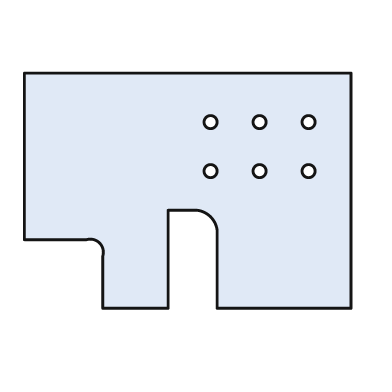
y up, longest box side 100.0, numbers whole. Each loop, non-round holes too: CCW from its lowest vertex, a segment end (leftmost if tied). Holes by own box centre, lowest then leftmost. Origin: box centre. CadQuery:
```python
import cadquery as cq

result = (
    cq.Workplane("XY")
    .moveTo(-26.0, -36.0)
    .lineTo(-6.0, -36.0)
    .lineTo(-6.0, -6.0)
    .lineTo(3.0, -6.0)
    .threePointArc((7.0, -8.0), (9.0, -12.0))
    .lineTo(9.0, -36.0)
    .lineTo(50.0, -36.0)
    .lineTo(50.0, 36.0)
    .lineTo(-50.0, 36.0)
    .lineTo(-50.0, -15.0)
    .lineTo(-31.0, -15.0)
    .threePointArc((-27.0, -16.0), (-26.0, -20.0))
    .close()
    .moveTo(7.0, 6.0)
    .circle(2.0)
    .moveTo(22.0, 6.0)
    .circle(2.0)
    .moveTo(37.0, 6.0)
    .circle(2.0)
    .moveTo(7.0, 21.0)
    .circle(2.0)
    .moveTo(22.0, 21.0)
    .circle(2.0)
    .moveTo(37.0, 21.0)
    .circle(2.0)
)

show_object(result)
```